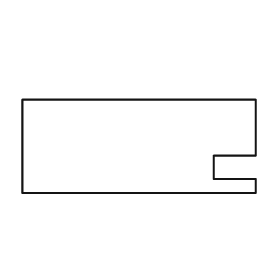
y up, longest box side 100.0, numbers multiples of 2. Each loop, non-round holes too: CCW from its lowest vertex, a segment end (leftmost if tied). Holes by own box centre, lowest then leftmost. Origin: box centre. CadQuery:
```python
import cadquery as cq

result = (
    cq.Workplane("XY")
    .moveTo(-50.0, -20.0)
    .lineTo(50.0, -20.0)
    .lineTo(50.0, -14.0)
    .lineTo(32.0, -14.0)
    .lineTo(32.0, -4.0)
    .lineTo(50.0, -4.0)
    .lineTo(50.0, 20.0)
    .lineTo(-50.0, 20.0)
    .close()
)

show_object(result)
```